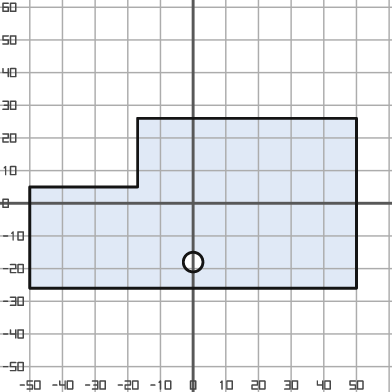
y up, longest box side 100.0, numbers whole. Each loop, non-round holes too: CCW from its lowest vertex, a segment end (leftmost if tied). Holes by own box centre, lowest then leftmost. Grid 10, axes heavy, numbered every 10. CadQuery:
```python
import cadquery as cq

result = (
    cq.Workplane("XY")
    .moveTo(-50.0, -26.0)
    .lineTo(50.0, -26.0)
    .lineTo(50.0, 26.0)
    .lineTo(-17.0, 26.0)
    .lineTo(-17.0, 5.0)
    .lineTo(-50.0, 5.0)
    .close()
    .moveTo(0.0, -18.0)
    .circle(3.0)
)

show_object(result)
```